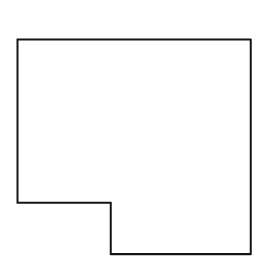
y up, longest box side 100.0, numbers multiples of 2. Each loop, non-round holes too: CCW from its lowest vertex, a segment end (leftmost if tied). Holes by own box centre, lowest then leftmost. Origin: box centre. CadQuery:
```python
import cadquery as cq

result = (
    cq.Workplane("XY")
    .moveTo(-10.0, -46.0)
    .lineTo(50.0, -46.0)
    .lineTo(50.0, 46.0)
    .lineTo(-50.0, 46.0)
    .lineTo(-50.0, -24.0)
    .lineTo(-10.0, -24.0)
    .close()
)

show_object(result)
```